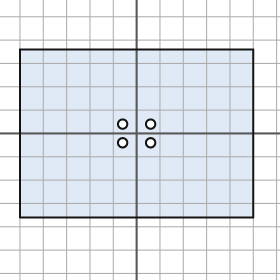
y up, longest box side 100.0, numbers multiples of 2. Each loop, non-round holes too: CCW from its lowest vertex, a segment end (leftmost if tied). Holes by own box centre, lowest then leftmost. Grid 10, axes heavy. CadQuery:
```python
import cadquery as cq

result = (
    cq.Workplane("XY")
    .moveTo(-50.0, -36.0)
    .lineTo(50.0, -36.0)
    .lineTo(50.0, 36.0)
    .lineTo(-50.0, 36.0)
    .close()
    .moveTo(-6.0, -4.0)
    .circle(2.0)
    .moveTo(6.0, -4.0)
    .circle(2.0)
    .moveTo(-6.0, 4.0)
    .circle(2.0)
    .moveTo(6.0, 4.0)
    .circle(2.0)
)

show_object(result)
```